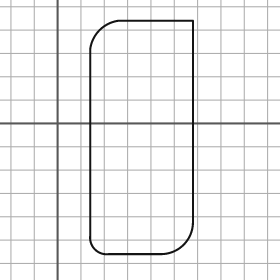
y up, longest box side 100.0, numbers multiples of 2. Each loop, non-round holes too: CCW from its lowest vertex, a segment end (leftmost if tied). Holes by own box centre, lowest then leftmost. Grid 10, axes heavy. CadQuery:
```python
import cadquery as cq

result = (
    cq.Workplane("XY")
    .moveTo(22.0, -56.0)
    .lineTo(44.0, -56.0)
    .threePointArc((54.0, -52.0), (58.0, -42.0))
    .lineTo(58.0, 44.0)
    .lineTo(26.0, 44.0)
    .threePointArc((18.0, 40.0), (14.0, 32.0))
    .lineTo(14.0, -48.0)
    .threePointArc((16.0, -54.0), (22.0, -56.0))
    .close()
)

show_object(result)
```